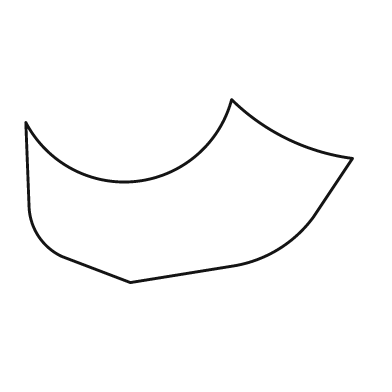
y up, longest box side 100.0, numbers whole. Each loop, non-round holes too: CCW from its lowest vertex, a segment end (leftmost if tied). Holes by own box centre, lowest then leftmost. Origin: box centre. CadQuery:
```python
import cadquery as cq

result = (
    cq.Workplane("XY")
    .moveTo(-18.0, -28.0)
    .lineTo(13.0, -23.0)
    .threePointArc((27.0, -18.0), (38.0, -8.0))
    .lineTo(50.0, 10.0)
    .threePointArc((30.0, 16.0), (13.0, 28.0))
    .threePointArc((-16.0, 3.0), (-50.0, 21.0))
    .lineTo(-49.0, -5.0)
    .threePointArc((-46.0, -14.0), (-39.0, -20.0))
    .close()
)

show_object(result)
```